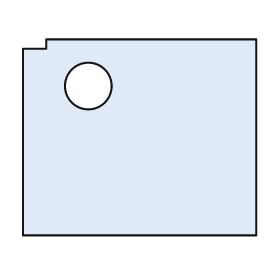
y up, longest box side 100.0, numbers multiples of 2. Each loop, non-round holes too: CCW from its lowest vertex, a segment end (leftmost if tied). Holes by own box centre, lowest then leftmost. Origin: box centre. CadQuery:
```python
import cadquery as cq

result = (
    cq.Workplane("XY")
    .moveTo(-50.0, -42.0)
    .lineTo(50.0, -42.0)
    .lineTo(50.0, 42.0)
    .lineTo(-40.0, 42.0)
    .lineTo(-40.0, 38.0)
    .lineTo(-50.0, 38.0)
    .close()
    .moveTo(-22.0, 22.0)
    .circle(10.0)
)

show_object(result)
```